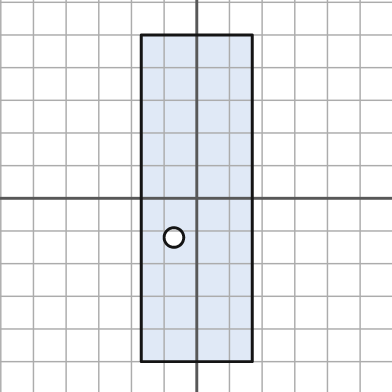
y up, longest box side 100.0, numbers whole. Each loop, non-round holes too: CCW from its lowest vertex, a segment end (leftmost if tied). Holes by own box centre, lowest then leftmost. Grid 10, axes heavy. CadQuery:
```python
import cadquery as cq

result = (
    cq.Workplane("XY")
    .moveTo(-17.0, -50.0)
    .lineTo(17.0, -50.0)
    .lineTo(17.0, 50.0)
    .lineTo(-17.0, 50.0)
    .close()
    .moveTo(-7.0, -12.0)
    .circle(3.0)
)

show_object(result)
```